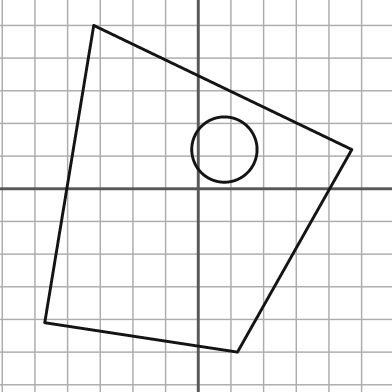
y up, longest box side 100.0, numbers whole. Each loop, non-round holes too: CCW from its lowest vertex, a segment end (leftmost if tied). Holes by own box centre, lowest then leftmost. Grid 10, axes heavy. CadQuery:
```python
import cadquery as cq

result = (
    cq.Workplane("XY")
    .moveTo(12.0, -50.0)
    .lineTo(47.0, 12.0)
    .lineTo(-32.0, 50.0)
    .lineTo(-47.0, -41.0)
    .close()
    .moveTo(8.0, 12.0)
    .circle(10.0)
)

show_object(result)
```